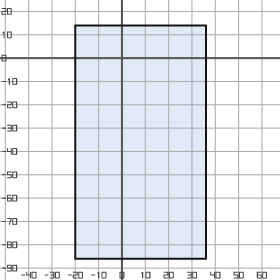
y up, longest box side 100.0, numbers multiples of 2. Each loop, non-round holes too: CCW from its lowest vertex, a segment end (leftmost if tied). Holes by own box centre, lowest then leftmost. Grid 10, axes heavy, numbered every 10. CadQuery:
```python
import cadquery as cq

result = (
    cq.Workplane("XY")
    .moveTo(-20.0, -86.0)
    .lineTo(36.0, -86.0)
    .lineTo(36.0, 14.0)
    .lineTo(-20.0, 14.0)
    .close()
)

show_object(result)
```